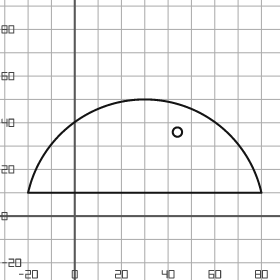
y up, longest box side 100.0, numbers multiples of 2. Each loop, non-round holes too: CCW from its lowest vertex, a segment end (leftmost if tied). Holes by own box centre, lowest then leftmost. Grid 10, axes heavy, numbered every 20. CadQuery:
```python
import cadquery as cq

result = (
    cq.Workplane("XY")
    .moveTo(-20.0, 10.0)
    .lineTo(80.0, 10.0)
    .threePointArc((30.0, 50.0), (-20.0, 10.0))
    .close()
    .moveTo(44.0, 36.0)
    .circle(2.0)
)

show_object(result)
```